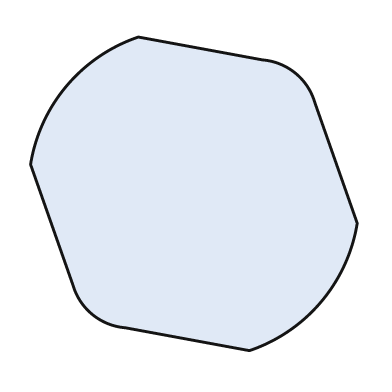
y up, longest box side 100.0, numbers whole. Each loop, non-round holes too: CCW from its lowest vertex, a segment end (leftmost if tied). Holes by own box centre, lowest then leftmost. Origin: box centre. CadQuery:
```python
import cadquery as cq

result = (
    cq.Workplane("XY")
    .moveTo(17.0, -48.0)
    .threePointArc((39.0, -33.0), (50.0, -9.0))
    .lineTo(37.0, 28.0)
    .threePointArc((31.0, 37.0), (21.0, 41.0))
    .lineTo(-17.0, 48.0)
    .threePointArc((-39.0, 33.0), (-50.0, 9.0))
    .lineTo(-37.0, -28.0)
    .threePointArc((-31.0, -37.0), (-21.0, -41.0))
    .close()
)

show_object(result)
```